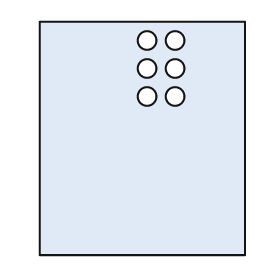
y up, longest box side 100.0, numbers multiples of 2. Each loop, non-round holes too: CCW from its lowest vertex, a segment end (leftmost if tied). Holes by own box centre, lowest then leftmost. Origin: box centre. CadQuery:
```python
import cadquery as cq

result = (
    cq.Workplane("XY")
    .moveTo(-44.0, -50.0)
    .lineTo(44.0, -50.0)
    .lineTo(44.0, 50.0)
    .lineTo(-44.0, 50.0)
    .close()
    .moveTo(2.0, 18.0)
    .circle(4.0)
    .moveTo(14.0, 18.0)
    .circle(4.0)
    .moveTo(2.0, 30.0)
    .circle(4.0)
    .moveTo(14.0, 30.0)
    .circle(4.0)
    .moveTo(2.0, 42.0)
    .circle(4.0)
    .moveTo(14.0, 42.0)
    .circle(4.0)
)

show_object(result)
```